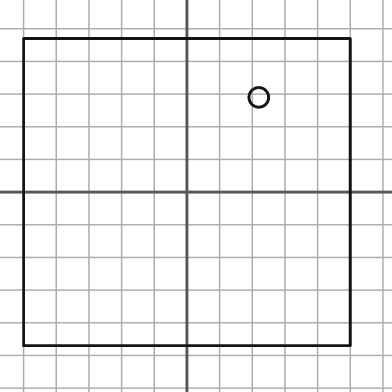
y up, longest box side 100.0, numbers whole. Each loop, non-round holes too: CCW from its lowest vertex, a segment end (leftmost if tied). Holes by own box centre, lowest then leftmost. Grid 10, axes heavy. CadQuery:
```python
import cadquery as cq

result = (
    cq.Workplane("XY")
    .moveTo(-50.0, -47.0)
    .lineTo(50.0, -47.0)
    .lineTo(50.0, 47.0)
    .lineTo(-50.0, 47.0)
    .close()
    .moveTo(22.0, 29.0)
    .circle(3.0)
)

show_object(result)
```